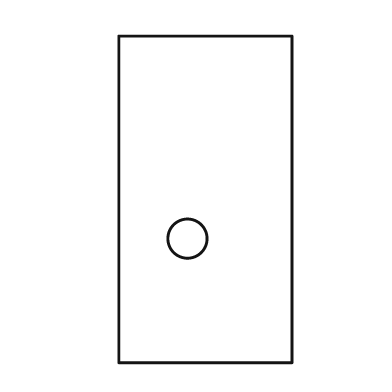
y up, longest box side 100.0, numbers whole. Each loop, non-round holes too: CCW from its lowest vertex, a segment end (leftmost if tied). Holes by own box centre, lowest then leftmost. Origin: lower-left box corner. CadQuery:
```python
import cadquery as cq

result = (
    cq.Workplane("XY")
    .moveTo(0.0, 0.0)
    .lineTo(53.0, 0.0)
    .lineTo(53.0, 100.0)
    .lineTo(0.0, 100.0)
    .close()
    .moveTo(21.0, 38.0)
    .circle(6.0)
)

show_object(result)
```